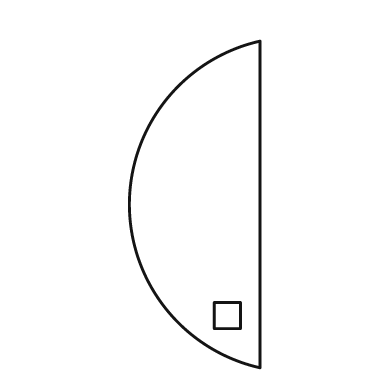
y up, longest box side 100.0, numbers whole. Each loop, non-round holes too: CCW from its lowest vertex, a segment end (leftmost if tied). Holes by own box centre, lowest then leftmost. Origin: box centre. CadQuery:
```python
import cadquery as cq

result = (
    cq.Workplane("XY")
    .moveTo(20.0, -50.0)
    .lineTo(20.0, 50.0)
    .threePointArc((-20.0, 0.0), (20.0, -50.0))
    .close()
    .moveTo(6.0, -38.0)
    .lineTo(14.0, -38.0)
    .lineTo(14.0, -30.0)
    .lineTo(6.0, -30.0)
    .close()
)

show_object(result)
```